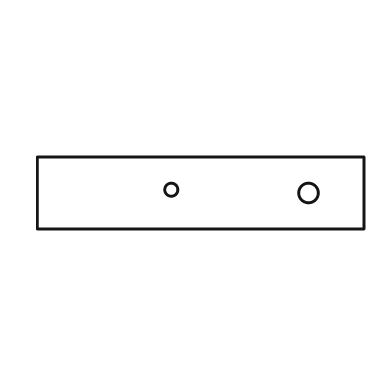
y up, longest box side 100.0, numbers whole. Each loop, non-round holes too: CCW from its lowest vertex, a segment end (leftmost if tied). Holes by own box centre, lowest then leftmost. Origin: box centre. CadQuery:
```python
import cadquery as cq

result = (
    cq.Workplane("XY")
    .moveTo(-50.0, -11.0)
    .lineTo(50.0, -11.0)
    .lineTo(50.0, 11.0)
    .lineTo(-50.0, 11.0)
    .close()
    .moveTo(33.0, 0.0)
    .circle(3.0)
    .moveTo(-9.0, 1.0)
    .circle(2.0)
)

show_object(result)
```